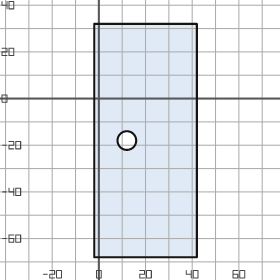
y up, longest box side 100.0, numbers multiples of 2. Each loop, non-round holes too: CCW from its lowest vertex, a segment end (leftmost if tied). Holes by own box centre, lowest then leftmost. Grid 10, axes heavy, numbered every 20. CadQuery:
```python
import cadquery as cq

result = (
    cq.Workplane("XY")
    .moveTo(-2.0, -68.0)
    .lineTo(42.0, -68.0)
    .lineTo(42.0, 32.0)
    .lineTo(-2.0, 32.0)
    .close()
    .moveTo(12.0, -18.0)
    .circle(4.0)
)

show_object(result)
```